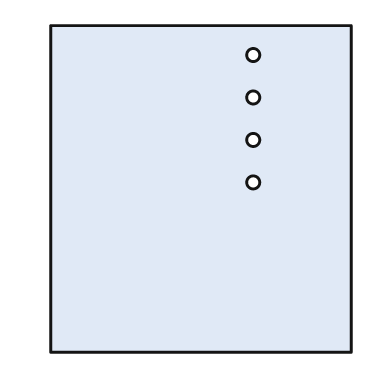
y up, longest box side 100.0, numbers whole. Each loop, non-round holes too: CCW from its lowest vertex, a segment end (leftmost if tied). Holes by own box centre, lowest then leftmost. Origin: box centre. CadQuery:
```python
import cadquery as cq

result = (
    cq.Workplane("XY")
    .moveTo(-46.0, -50.0)
    .lineTo(46.0, -50.0)
    .lineTo(46.0, 50.0)
    .lineTo(-46.0, 50.0)
    .close()
    .moveTo(16.0, 2.0)
    .circle(2.0)
    .moveTo(16.0, 15.0)
    .circle(2.0)
    .moveTo(16.0, 28.0)
    .circle(2.0)
    .moveTo(16.0, 41.0)
    .circle(2.0)
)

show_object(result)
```